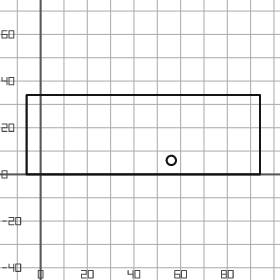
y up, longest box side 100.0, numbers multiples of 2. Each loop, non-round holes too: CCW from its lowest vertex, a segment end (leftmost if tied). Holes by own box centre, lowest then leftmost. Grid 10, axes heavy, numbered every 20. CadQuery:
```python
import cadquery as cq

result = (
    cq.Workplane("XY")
    .moveTo(-6.0, 0.0)
    .lineTo(94.0, 0.0)
    .lineTo(94.0, 34.0)
    .lineTo(-6.0, 34.0)
    .close()
    .moveTo(56.0, 6.0)
    .circle(2.0)
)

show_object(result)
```